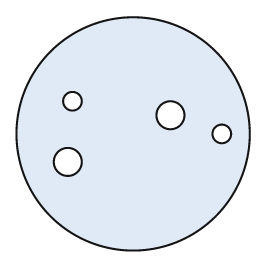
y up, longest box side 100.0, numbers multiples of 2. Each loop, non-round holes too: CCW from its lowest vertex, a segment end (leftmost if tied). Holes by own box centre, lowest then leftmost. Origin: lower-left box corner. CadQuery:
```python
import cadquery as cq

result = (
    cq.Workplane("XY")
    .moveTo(50.0, 50.0)
    .circle(50.0)
    .moveTo(22.0, 38.0)
    .circle(6.0)
    .moveTo(88.0, 50.0)
    .circle(4.0)
    .moveTo(66.0, 58.0)
    .circle(6.0)
    .moveTo(24.0, 64.0)
    .circle(4.0)
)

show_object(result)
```